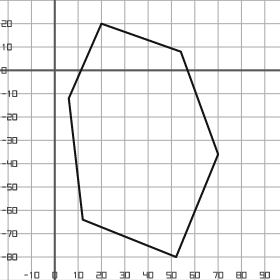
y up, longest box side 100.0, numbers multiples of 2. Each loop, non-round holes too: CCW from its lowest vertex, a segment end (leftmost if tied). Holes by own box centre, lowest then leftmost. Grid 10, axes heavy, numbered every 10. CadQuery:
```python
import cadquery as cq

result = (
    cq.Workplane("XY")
    .moveTo(52.0, -80.0)
    .lineTo(70.0, -36.0)
    .lineTo(54.0, 8.0)
    .lineTo(20.0, 20.0)
    .lineTo(6.0, -12.0)
    .lineTo(12.0, -64.0)
    .close()
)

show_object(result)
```